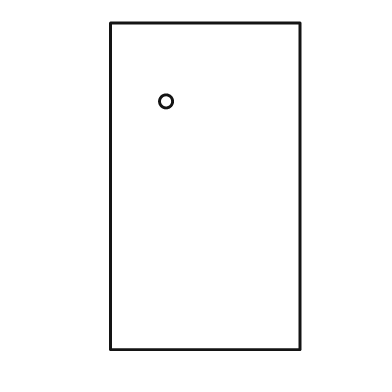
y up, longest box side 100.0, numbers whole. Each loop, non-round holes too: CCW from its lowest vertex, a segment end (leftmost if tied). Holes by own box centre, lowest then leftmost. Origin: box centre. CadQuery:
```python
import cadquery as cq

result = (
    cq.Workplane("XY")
    .moveTo(-29.0, -50.0)
    .lineTo(29.0, -50.0)
    .lineTo(29.0, 50.0)
    .lineTo(-29.0, 50.0)
    .close()
    .moveTo(-12.0, 26.0)
    .circle(2.0)
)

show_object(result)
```